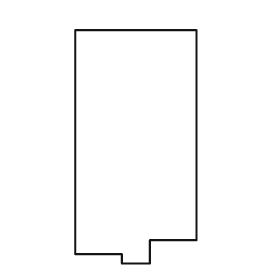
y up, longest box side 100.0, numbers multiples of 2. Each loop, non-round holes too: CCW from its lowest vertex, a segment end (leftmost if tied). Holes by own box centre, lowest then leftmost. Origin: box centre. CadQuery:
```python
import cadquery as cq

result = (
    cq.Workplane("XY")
    .moveTo(-6.0, -50.0)
    .lineTo(6.0, -50.0)
    .lineTo(6.0, -40.0)
    .lineTo(26.0, -40.0)
    .lineTo(26.0, 50.0)
    .lineTo(-26.0, 50.0)
    .lineTo(-26.0, -46.0)
    .lineTo(-6.0, -46.0)
    .close()
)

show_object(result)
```